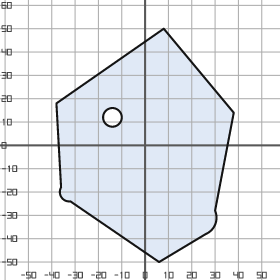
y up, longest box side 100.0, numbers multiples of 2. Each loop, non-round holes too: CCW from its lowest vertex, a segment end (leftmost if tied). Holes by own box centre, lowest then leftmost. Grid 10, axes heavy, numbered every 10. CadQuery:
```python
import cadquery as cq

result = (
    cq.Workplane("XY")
    .moveTo(6.0, -50.0)
    .lineTo(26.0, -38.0)
    .threePointArc((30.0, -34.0), (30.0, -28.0))
    .lineTo(38.0, 14.0)
    .lineTo(8.0, 50.0)
    .lineTo(-38.0, 18.0)
    .lineTo(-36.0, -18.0)
    .threePointArc((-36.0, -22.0), (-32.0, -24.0))
    .close()
    .moveTo(-14.0, 12.0)
    .circle(4.0)
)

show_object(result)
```